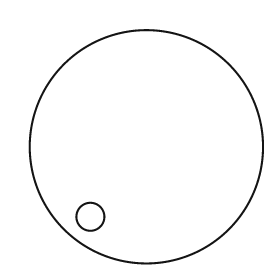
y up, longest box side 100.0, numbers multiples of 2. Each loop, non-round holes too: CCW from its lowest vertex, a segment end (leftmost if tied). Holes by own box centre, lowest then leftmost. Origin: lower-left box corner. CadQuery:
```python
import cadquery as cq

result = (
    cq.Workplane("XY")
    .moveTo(50.0, 50.0)
    .circle(50.0)
    .moveTo(26.0, 20.0)
    .circle(6.0)
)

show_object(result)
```